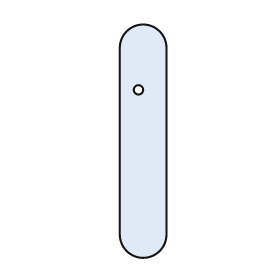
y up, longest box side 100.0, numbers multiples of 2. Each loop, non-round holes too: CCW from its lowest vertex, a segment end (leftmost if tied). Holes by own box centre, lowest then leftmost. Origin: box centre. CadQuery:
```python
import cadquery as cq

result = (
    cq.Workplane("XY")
    .moveTo(-10.0, -40.0)
    .threePointArc((0.0, -50.0), (10.0, -40.0))
    .lineTo(10.0, 40.0)
    .threePointArc((0.0, 50.0), (-10.0, 40.0))
    .close()
    .moveTo(-2.0, 22.0)
    .circle(2.0)
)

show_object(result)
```